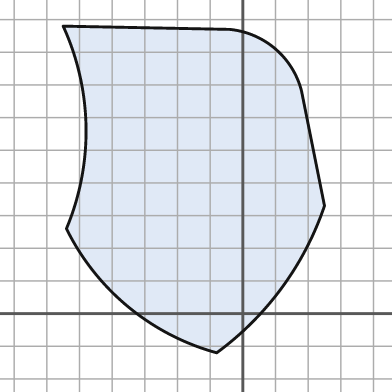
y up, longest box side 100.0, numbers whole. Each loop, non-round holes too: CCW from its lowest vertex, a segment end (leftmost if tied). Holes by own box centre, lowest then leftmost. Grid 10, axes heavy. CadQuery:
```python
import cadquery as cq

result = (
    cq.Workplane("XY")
    .moveTo(-8.0, -12.0)
    .threePointArc((12.0, 8.0), (25.0, 33.0))
    .lineTo(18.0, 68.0)
    .threePointArc((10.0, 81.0), (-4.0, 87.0))
    .lineTo(-55.0, 88.0)
    .threePointArc((-48.0, 57.0), (-54.0, 26.0))
    .threePointArc((-35.0, 2.0), (-8.0, -12.0))
    .close()
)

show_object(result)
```